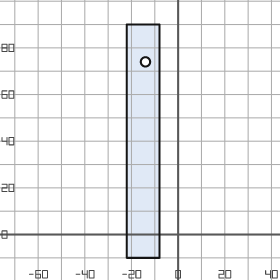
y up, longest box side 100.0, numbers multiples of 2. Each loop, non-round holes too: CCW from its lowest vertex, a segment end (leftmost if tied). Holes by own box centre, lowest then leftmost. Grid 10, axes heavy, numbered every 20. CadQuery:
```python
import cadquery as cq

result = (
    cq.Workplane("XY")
    .moveTo(-22.0, -10.0)
    .lineTo(-8.0, -10.0)
    .lineTo(-8.0, 90.0)
    .lineTo(-22.0, 90.0)
    .close()
    .moveTo(-14.0, 74.0)
    .circle(2.0)
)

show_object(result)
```